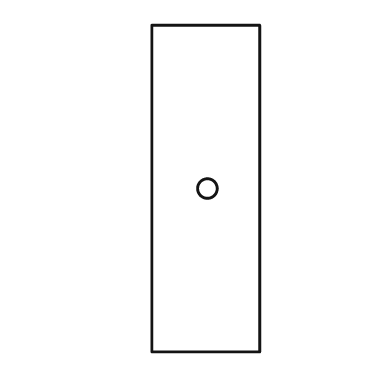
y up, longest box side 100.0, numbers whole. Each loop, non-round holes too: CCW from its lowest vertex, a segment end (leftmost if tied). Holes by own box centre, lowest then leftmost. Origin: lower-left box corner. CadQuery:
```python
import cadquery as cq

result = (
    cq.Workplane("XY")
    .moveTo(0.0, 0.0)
    .lineTo(33.0, 0.0)
    .lineTo(33.0, 100.0)
    .lineTo(0.0, 100.0)
    .close()
    .moveTo(17.0, 50.0)
    .circle(3.0)
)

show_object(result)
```